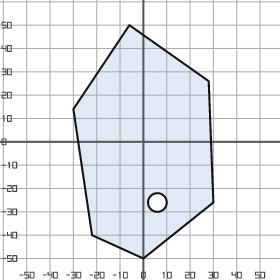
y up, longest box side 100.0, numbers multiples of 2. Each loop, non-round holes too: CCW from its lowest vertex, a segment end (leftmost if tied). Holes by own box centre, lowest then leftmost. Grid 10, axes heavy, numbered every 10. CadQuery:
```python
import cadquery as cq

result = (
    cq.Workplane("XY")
    .moveTo(0.0, -50.0)
    .lineTo(30.0, -26.0)
    .lineTo(28.0, 26.0)
    .lineTo(-6.0, 50.0)
    .lineTo(-30.0, 14.0)
    .lineTo(-22.0, -40.0)
    .close()
    .moveTo(6.0, -26.0)
    .circle(4.0)
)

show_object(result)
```